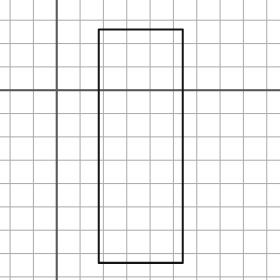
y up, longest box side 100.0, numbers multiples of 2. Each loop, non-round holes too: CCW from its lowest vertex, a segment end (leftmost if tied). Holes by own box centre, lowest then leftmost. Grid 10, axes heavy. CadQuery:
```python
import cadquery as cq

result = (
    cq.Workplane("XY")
    .moveTo(18.0, -74.0)
    .lineTo(54.0, -74.0)
    .lineTo(54.0, 26.0)
    .lineTo(18.0, 26.0)
    .close()
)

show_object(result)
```